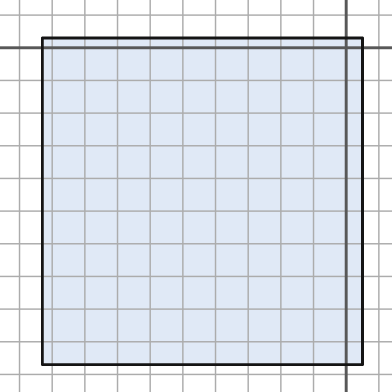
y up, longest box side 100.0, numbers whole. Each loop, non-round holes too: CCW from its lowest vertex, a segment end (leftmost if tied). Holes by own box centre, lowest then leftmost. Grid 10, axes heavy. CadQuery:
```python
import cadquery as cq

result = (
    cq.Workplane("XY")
    .moveTo(-93.0, -97.0)
    .lineTo(5.0, -97.0)
    .lineTo(5.0, 3.0)
    .lineTo(-93.0, 3.0)
    .close()
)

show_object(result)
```